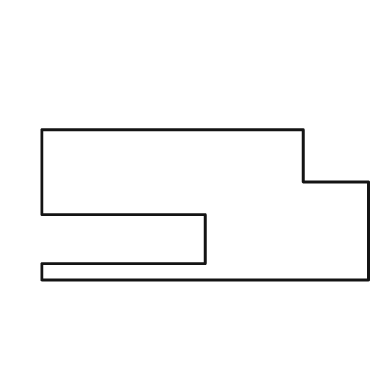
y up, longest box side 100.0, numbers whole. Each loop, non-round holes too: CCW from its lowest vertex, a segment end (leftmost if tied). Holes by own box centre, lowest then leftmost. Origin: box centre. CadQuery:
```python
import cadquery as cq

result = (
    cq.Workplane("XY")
    .moveTo(-50.0, -23.0)
    .lineTo(50.0, -23.0)
    .lineTo(50.0, 7.0)
    .lineTo(30.0, 7.0)
    .lineTo(30.0, 23.0)
    .lineTo(-50.0, 23.0)
    .lineTo(-50.0, -3.0)
    .lineTo(0.0, -3.0)
    .lineTo(0.0, -18.0)
    .lineTo(-50.0, -18.0)
    .close()
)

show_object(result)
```